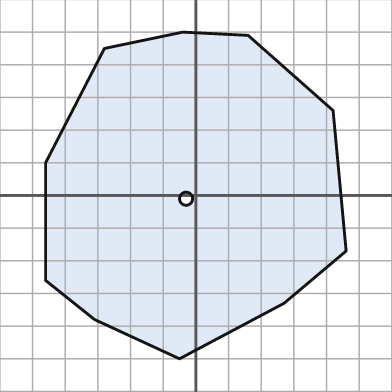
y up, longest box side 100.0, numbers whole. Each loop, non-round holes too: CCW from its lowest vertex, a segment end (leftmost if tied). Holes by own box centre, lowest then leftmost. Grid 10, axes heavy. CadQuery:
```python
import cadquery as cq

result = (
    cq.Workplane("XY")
    .moveTo(-5.0, -50.0)
    .lineTo(27.0, -33.0)
    .lineTo(46.0, -17.0)
    .lineTo(42.0, 26.0)
    .lineTo(16.0, 49.0)
    .lineTo(-4.0, 50.0)
    .lineTo(-28.0, 45.0)
    .lineTo(-46.0, 10.0)
    .lineTo(-46.0, -26.0)
    .lineTo(-31.0, -38.0)
    .close()
    .moveTo(-3.0, -1.0)
    .circle(2.0)
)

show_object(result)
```